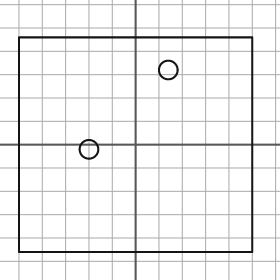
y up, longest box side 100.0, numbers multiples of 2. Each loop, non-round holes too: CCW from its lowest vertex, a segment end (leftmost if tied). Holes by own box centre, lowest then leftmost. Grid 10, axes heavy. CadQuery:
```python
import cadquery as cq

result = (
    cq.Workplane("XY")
    .moveTo(-50.0, -46.0)
    .lineTo(50.0, -46.0)
    .lineTo(50.0, 46.0)
    .lineTo(-50.0, 46.0)
    .close()
    .moveTo(-20.0, -2.0)
    .circle(4.0)
    .moveTo(14.0, 32.0)
    .circle(4.0)
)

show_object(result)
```